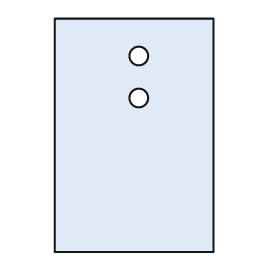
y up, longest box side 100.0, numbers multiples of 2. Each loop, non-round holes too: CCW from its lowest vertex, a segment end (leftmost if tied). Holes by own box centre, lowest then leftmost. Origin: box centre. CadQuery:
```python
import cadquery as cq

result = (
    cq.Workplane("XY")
    .moveTo(-34.0, -50.0)
    .lineTo(34.0, -50.0)
    .lineTo(34.0, 50.0)
    .lineTo(-34.0, 50.0)
    .close()
    .moveTo(2.0, 16.0)
    .circle(4.0)
    .moveTo(2.0, 34.0)
    .circle(4.0)
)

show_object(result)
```